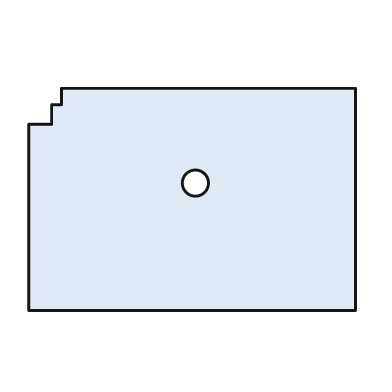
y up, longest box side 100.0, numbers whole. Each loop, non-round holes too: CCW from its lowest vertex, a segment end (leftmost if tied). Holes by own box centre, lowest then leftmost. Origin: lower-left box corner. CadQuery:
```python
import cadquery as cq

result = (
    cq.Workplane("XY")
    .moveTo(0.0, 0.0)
    .lineTo(100.0, 0.0)
    .lineTo(100.0, 68.0)
    .lineTo(10.0, 68.0)
    .lineTo(10.0, 63.0)
    .lineTo(7.0, 63.0)
    .lineTo(7.0, 57.0)
    .lineTo(0.0, 57.0)
    .close()
    .moveTo(51.0, 39.0)
    .circle(4.0)
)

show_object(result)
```